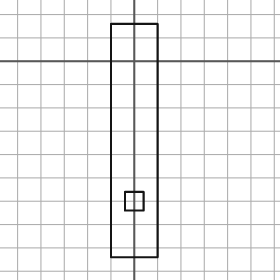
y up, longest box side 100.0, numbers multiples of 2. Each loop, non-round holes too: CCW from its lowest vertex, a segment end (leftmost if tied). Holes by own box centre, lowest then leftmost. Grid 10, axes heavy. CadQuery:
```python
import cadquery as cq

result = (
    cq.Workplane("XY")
    .moveTo(-10.0, -84.0)
    .lineTo(10.0, -84.0)
    .lineTo(10.0, 16.0)
    .lineTo(-10.0, 16.0)
    .close()
    .moveTo(-4.0, -64.0)
    .lineTo(4.0, -64.0)
    .lineTo(4.0, -56.0)
    .lineTo(-4.0, -56.0)
    .close()
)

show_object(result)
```